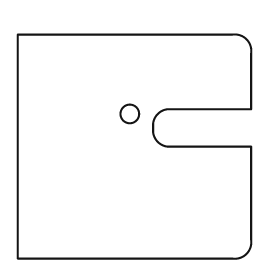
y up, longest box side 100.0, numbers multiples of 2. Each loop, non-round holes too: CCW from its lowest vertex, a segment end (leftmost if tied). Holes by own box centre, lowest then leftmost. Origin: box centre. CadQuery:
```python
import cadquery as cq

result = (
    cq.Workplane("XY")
    .moveTo(-50.0, -48.0)
    .lineTo(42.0, -48.0)
    .threePointArc((48.0, -46.0), (50.0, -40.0))
    .lineTo(50.0, 0.0)
    .lineTo(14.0, 0.0)
    .threePointArc((10.0, 2.0), (8.0, 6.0))
    .lineTo(8.0, 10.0)
    .threePointArc((10.0, 14.0), (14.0, 16.0))
    .lineTo(50.0, 16.0)
    .lineTo(50.0, 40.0)
    .threePointArc((48.0, 46.0), (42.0, 48.0))
    .lineTo(-50.0, 48.0)
    .close()
    .moveTo(-2.0, 14.0)
    .circle(4.0)
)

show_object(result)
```